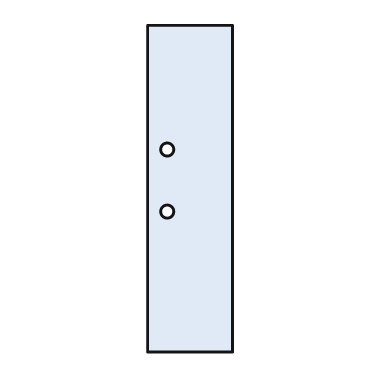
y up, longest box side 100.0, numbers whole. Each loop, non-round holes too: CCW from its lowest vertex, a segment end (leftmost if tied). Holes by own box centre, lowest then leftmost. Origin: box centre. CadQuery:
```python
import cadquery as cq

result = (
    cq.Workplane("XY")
    .moveTo(-13.0, -50.0)
    .lineTo(13.0, -50.0)
    .lineTo(13.0, 50.0)
    .lineTo(-13.0, 50.0)
    .close()
    .moveTo(-7.0, -7.0)
    .circle(2.0)
    .moveTo(-7.0, 12.0)
    .circle(2.0)
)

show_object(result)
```